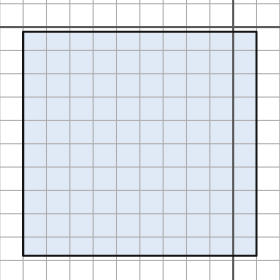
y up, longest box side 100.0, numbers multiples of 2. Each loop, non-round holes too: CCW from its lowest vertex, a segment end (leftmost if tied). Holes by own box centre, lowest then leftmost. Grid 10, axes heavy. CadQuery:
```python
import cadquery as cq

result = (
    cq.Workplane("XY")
    .moveTo(-90.0, -98.0)
    .lineTo(10.0, -98.0)
    .lineTo(10.0, -2.0)
    .lineTo(-90.0, -2.0)
    .close()
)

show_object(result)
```